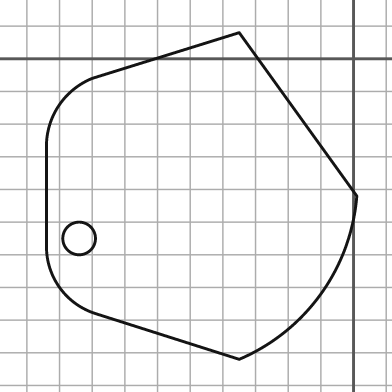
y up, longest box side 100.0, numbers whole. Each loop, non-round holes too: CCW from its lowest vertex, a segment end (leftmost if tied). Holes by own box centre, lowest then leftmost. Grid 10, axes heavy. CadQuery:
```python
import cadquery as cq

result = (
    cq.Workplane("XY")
    .moveTo(-35.0, -92.0)
    .threePointArc((-10.0, -72.0), (1.0, -42.0))
    .lineTo(-35.0, 8.0)
    .lineTo(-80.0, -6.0)
    .threePointArc((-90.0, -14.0), (-94.0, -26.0))
    .lineTo(-94.0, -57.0)
    .threePointArc((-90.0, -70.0), (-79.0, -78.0))
    .close()
    .moveTo(-84.0, -55.0)
    .circle(5.0)
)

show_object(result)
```